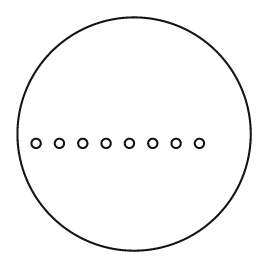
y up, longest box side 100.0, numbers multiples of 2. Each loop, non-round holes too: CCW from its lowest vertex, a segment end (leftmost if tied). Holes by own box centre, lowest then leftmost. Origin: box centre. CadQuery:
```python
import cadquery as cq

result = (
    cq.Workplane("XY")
    .moveTo(0.0, 0.0)
    .circle(50.0)
    .moveTo(-42.0, -4.0)
    .circle(2.0)
    .moveTo(-32.0, -4.0)
    .circle(2.0)
    .moveTo(-22.0, -4.0)
    .circle(2.0)
    .moveTo(-12.0, -4.0)
    .circle(2.0)
    .moveTo(-2.0, -4.0)
    .circle(2.0)
    .moveTo(8.0, -4.0)
    .circle(2.0)
    .moveTo(18.0, -4.0)
    .circle(2.0)
    .moveTo(28.0, -4.0)
    .circle(2.0)
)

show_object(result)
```